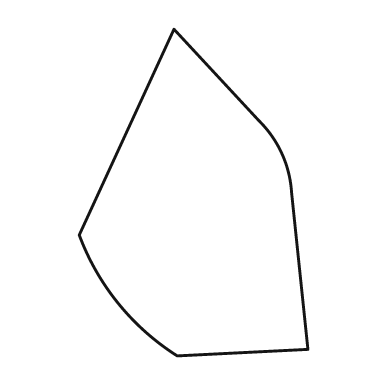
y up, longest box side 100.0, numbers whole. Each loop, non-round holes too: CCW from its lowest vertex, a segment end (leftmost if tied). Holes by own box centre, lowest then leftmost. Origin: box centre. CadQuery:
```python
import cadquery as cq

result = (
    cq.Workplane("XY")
    .moveTo(-5.0, -50.0)
    .lineTo(35.0, -48.0)
    .lineTo(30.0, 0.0)
    .threePointArc((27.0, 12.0), (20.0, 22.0))
    .lineTo(-6.0, 50.0)
    .lineTo(-35.0, -13.0)
    .threePointArc((-23.0, -34.0), (-5.0, -50.0))
    .close()
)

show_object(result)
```